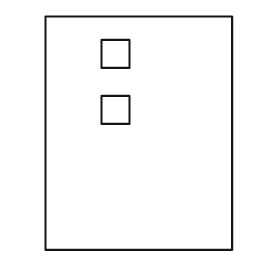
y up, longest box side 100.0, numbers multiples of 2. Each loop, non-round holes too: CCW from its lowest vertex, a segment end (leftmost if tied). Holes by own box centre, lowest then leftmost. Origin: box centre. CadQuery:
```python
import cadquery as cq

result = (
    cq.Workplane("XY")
    .moveTo(-40.0, -50.0)
    .lineTo(40.0, -50.0)
    .lineTo(40.0, 50.0)
    .lineTo(-40.0, 50.0)
    .close()
    .moveTo(-16.0, 4.0)
    .lineTo(-4.0, 4.0)
    .lineTo(-4.0, 16.0)
    .lineTo(-16.0, 16.0)
    .close()
    .moveTo(-16.0, 28.0)
    .lineTo(-4.0, 28.0)
    .lineTo(-4.0, 40.0)
    .lineTo(-16.0, 40.0)
    .close()
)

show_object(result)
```